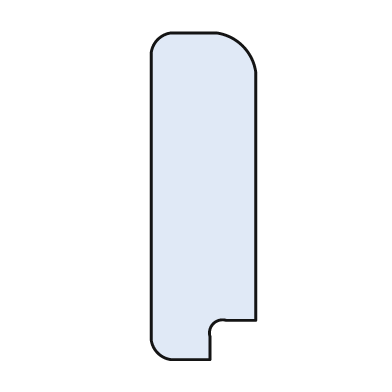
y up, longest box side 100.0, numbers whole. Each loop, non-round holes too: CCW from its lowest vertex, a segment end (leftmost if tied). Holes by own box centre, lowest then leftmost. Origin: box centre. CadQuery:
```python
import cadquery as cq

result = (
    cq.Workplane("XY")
    .moveTo(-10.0, -50.0)
    .lineTo(2.0, -50.0)
    .lineTo(2.0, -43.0)
    .threePointArc((3.0, -39.0), (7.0, -38.0))
    .lineTo(16.0, -38.0)
    .lineTo(16.0, 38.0)
    .threePointArc((12.0, 46.0), (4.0, 50.0))
    .lineTo(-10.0, 50.0)
    .threePointArc((-14.0, 48.0), (-16.0, 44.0))
    .lineTo(-16.0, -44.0)
    .threePointArc((-14.0, -48.0), (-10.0, -50.0))
    .close()
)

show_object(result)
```